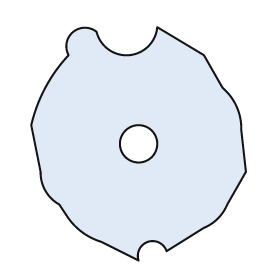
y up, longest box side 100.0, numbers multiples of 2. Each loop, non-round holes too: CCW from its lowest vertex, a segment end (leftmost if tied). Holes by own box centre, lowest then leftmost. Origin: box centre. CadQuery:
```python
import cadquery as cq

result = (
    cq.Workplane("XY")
    .moveTo(0.0, -50.0)
    .threePointArc((4.0, -42.0), (12.0, -46.0))
    .lineTo(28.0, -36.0)
    .threePointArc((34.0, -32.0), (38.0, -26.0))
    .lineTo(46.0, -12.0)
    .lineTo(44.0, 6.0)
    .threePointArc((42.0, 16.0), (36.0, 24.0))
    .lineTo(28.0, 38.0)
    .lineTo(8.0, 50.0)
    .threePointArc((-4.0, 38.0), (-18.0, 48.0))
    .threePointArc((-28.0, 48.0), (-30.0, 38.0))
    .threePointArc((-40.0, 24.0), (-46.0, 8.0))
    .lineTo(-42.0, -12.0)
    .threePointArc((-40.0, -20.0), (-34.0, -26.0))
    .lineTo(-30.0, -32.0)
    .threePointArc((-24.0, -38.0), (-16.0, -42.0))
    .close()
    .moveTo(0.0, 0.0)
    .circle(8.0)
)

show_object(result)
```